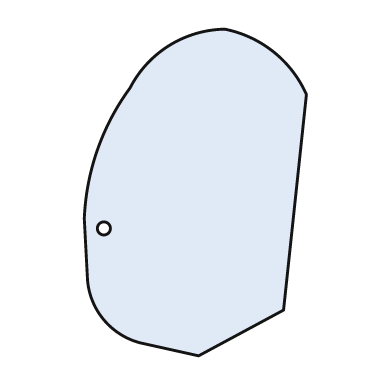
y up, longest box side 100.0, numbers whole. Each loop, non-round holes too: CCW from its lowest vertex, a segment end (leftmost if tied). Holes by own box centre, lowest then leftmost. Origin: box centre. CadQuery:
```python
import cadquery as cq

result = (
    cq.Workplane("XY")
    .moveTo(1.0, -50.0)
    .lineTo(27.0, -36.0)
    .lineTo(34.0, 30.0)
    .threePointArc((24.0, 43.0), (9.0, 50.0))
    .threePointArc((-8.0, 45.0), (-20.0, 32.0))
    .threePointArc((-30.0, 13.0), (-34.0, -8.0))
    .lineTo(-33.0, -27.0)
    .threePointArc((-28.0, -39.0), (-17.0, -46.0))
    .close()
    .moveTo(-28.0, -11.0)
    .circle(2.0)
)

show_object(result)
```